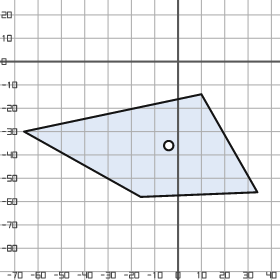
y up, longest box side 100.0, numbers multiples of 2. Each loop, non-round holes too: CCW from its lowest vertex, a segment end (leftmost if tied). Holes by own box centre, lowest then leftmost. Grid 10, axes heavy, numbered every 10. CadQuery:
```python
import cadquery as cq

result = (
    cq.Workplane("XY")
    .moveTo(-16.0, -58.0)
    .lineTo(34.0, -56.0)
    .lineTo(10.0, -14.0)
    .lineTo(-66.0, -30.0)
    .close()
    .moveTo(-4.0, -36.0)
    .circle(2.0)
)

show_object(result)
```